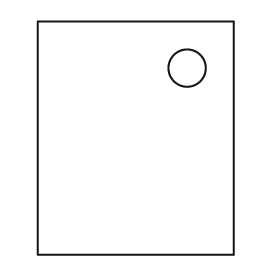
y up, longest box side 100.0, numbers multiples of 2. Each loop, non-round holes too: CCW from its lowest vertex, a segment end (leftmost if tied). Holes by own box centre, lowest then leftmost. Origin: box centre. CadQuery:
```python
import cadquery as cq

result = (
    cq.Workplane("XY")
    .moveTo(-42.0, -50.0)
    .lineTo(42.0, -50.0)
    .lineTo(42.0, 50.0)
    .lineTo(-42.0, 50.0)
    .close()
    .moveTo(22.0, 30.0)
    .circle(8.0)
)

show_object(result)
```